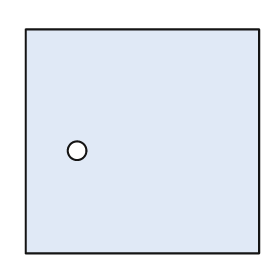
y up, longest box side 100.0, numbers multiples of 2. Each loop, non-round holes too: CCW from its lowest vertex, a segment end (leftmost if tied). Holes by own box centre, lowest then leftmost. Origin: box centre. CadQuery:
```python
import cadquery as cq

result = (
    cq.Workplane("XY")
    .moveTo(-50.0, -48.0)
    .lineTo(50.0, -48.0)
    .lineTo(50.0, 48.0)
    .lineTo(-50.0, 48.0)
    .close()
    .moveTo(-28.0, -4.0)
    .circle(4.0)
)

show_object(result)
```